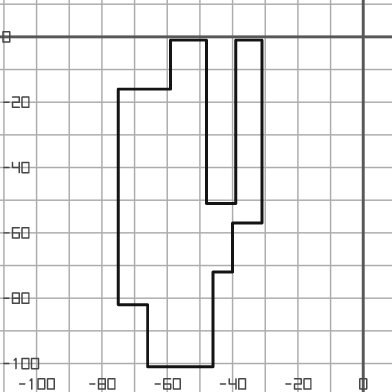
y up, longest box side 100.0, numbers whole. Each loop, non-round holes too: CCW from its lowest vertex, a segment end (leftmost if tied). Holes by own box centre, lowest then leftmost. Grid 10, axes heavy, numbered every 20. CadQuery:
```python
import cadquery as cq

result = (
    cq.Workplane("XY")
    .moveTo(-66.0, -101.0)
    .lineTo(-46.0, -101.0)
    .lineTo(-46.0, -72.0)
    .lineTo(-40.0, -72.0)
    .lineTo(-40.0, -57.0)
    .lineTo(-31.0, -57.0)
    .lineTo(-31.0, -1.0)
    .lineTo(-39.0, -1.0)
    .lineTo(-39.0, -51.0)
    .lineTo(-48.0, -51.0)
    .lineTo(-48.0, -1.0)
    .lineTo(-59.0, -1.0)
    .lineTo(-59.0, -16.0)
    .lineTo(-75.0, -16.0)
    .lineTo(-75.0, -82.0)
    .lineTo(-66.0, -82.0)
    .close()
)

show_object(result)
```